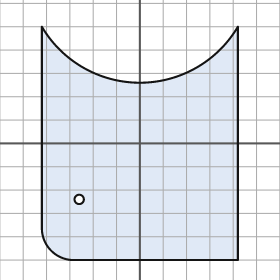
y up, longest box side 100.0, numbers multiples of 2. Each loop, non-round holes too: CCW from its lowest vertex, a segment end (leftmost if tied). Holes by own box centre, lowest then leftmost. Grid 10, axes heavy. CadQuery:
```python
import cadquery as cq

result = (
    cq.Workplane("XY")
    .moveTo(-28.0, -50.0)
    .lineTo(42.0, -50.0)
    .lineTo(42.0, 50.0)
    .threePointArc((0.0, 26.0), (-42.0, 50.0))
    .lineTo(-42.0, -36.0)
    .threePointArc((-38.0, -46.0), (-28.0, -50.0))
    .close()
    .moveTo(-26.0, -24.0)
    .circle(2.0)
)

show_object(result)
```